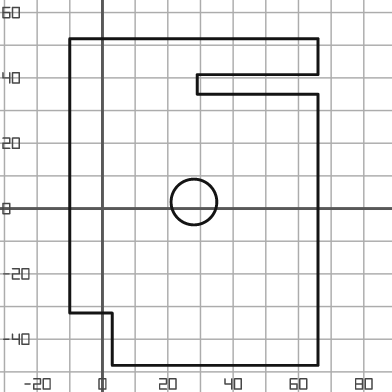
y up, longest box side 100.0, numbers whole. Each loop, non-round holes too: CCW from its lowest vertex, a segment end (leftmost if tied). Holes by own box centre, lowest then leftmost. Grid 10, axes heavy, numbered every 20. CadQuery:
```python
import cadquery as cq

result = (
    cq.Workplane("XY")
    .moveTo(3.0, -48.0)
    .lineTo(66.0, -48.0)
    .lineTo(66.0, 35.0)
    .lineTo(29.0, 35.0)
    .lineTo(29.0, 41.0)
    .lineTo(66.0, 41.0)
    .lineTo(66.0, 52.0)
    .lineTo(-10.0, 52.0)
    .lineTo(-10.0, -32.0)
    .lineTo(3.0, -32.0)
    .close()
    .moveTo(28.0, 2.0)
    .circle(7.0)
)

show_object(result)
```